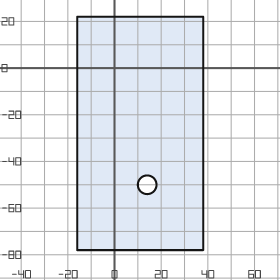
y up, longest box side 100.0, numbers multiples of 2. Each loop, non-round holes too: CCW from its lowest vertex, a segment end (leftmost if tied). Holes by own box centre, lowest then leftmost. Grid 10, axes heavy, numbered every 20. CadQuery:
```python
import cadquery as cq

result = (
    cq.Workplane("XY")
    .moveTo(-16.0, -78.0)
    .lineTo(38.0, -78.0)
    .lineTo(38.0, 22.0)
    .lineTo(-16.0, 22.0)
    .close()
    .moveTo(14.0, -50.0)
    .circle(4.0)
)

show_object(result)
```